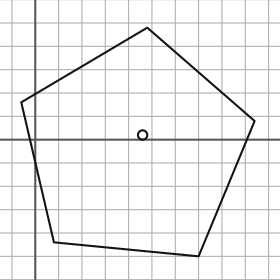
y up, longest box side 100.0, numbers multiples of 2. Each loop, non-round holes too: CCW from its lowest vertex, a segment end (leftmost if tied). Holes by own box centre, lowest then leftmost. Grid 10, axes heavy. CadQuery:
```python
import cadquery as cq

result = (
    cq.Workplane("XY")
    .moveTo(70.0, -50.0)
    .lineTo(94.0, 8.0)
    .lineTo(48.0, 48.0)
    .lineTo(-6.0, 16.0)
    .lineTo(8.0, -44.0)
    .close()
    .moveTo(46.0, 2.0)
    .circle(2.0)
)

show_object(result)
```